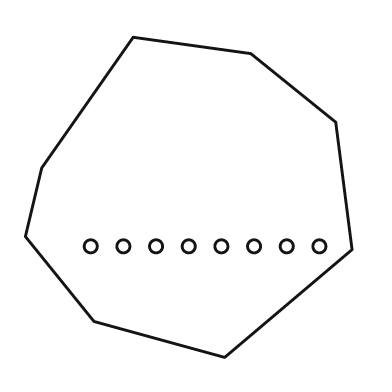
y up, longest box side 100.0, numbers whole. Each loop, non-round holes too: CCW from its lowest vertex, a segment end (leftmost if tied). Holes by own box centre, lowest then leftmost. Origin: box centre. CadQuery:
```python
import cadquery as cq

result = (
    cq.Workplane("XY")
    .moveTo(11.0, -49.0)
    .lineTo(50.0, -16.0)
    .lineTo(45.0, 23.0)
    .lineTo(19.0, 44.0)
    .lineTo(-17.0, 49.0)
    .lineTo(-45.0, 9.0)
    .lineTo(-50.0, -12.0)
    .lineTo(-29.0, -38.0)
    .close()
    .moveTo(-30.0, -15.0)
    .circle(2.0)
    .moveTo(-20.0, -15.0)
    .circle(2.0)
    .moveTo(-10.0, -15.0)
    .circle(2.0)
    .moveTo(0.0, -15.0)
    .circle(2.0)
    .moveTo(10.0, -15.0)
    .circle(2.0)
    .moveTo(20.0, -15.0)
    .circle(2.0)
    .moveTo(30.0, -15.0)
    .circle(2.0)
    .moveTo(40.0, -15.0)
    .circle(2.0)
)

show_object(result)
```